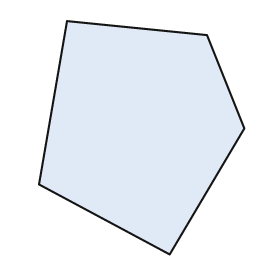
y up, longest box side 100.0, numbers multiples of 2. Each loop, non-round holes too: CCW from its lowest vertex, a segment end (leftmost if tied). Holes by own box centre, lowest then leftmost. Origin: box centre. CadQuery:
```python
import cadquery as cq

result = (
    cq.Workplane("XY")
    .moveTo(12.0, -50.0)
    .lineTo(44.0, 4.0)
    .lineTo(28.0, 44.0)
    .lineTo(-32.0, 50.0)
    .lineTo(-44.0, -20.0)
    .close()
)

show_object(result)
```